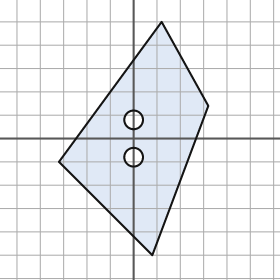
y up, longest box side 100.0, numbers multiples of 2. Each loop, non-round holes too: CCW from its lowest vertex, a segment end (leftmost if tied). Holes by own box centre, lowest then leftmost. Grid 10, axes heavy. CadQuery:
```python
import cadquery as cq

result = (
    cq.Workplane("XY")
    .moveTo(8.0, -50.0)
    .lineTo(32.0, 14.0)
    .lineTo(12.0, 50.0)
    .lineTo(-32.0, -10.0)
    .close()
    .moveTo(0.0, -8.0)
    .circle(4.0)
    .moveTo(0.0, 8.0)
    .circle(4.0)
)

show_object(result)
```